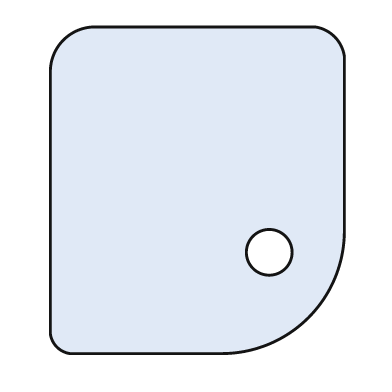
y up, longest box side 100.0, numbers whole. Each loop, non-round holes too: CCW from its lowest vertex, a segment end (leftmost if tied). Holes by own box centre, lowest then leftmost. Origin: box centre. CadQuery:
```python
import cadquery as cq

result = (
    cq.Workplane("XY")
    .moveTo(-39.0, -50.0)
    .lineTo(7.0, -50.0)
    .threePointArc((34.0, -39.0), (45.0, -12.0))
    .lineTo(45.0, 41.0)
    .threePointArc((42.0, 47.0), (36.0, 50.0))
    .lineTo(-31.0, 50.0)
    .threePointArc((-41.0, 46.0), (-45.0, 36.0))
    .lineTo(-45.0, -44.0)
    .threePointArc((-43.0, -48.0), (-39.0, -50.0))
    .close()
    .moveTo(22.0, -19.0)
    .circle(7.0)
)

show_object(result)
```